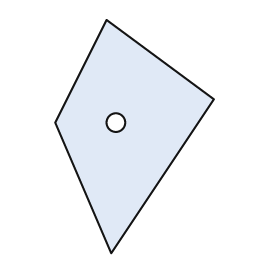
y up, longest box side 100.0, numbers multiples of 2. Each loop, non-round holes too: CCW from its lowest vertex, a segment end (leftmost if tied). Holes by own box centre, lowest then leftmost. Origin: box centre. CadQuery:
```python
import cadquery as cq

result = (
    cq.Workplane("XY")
    .moveTo(-10.0, -50.0)
    .lineTo(34.0, 16.0)
    .lineTo(-12.0, 50.0)
    .lineTo(-34.0, 6.0)
    .close()
    .moveTo(-8.0, 6.0)
    .circle(4.0)
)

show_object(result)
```